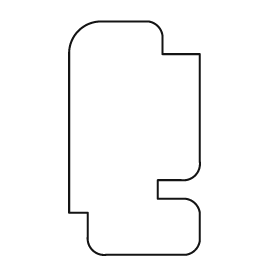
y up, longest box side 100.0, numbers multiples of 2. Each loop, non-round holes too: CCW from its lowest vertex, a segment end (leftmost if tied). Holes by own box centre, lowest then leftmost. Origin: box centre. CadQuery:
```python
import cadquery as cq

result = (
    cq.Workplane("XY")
    .moveTo(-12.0, -50.0)
    .lineTo(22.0, -50.0)
    .threePointArc((26.0, -48.0), (28.0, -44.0))
    .lineTo(28.0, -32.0)
    .threePointArc((26.0, -28.0), (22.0, -26.0))
    .lineTo(10.0, -26.0)
    .lineTo(10.0, -18.0)
    .lineTo(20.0, -18.0)
    .threePointArc((26.0, -16.0), (28.0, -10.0))
    .lineTo(28.0, 36.0)
    .lineTo(12.0, 36.0)
    .lineTo(12.0, 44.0)
    .threePointArc((10.0, 48.0), (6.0, 50.0))
    .lineTo(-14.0, 50.0)
    .threePointArc((-24.0, 46.0), (-28.0, 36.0))
    .lineTo(-28.0, -32.0)
    .lineTo(-20.0, -32.0)
    .lineTo(-20.0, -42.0)
    .threePointArc((-18.0, -48.0), (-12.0, -50.0))
    .close()
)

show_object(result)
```